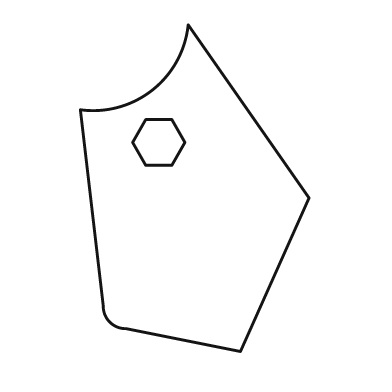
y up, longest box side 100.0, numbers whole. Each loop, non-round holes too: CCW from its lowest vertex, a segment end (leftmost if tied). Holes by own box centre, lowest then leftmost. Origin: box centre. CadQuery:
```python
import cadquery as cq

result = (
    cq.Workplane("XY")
    .moveTo(14.0, -50.0)
    .lineTo(35.0, -3.0)
    .lineTo(-2.0, 50.0)
    .threePointArc((-13.0, 30.0), (-35.0, 24.0))
    .lineTo(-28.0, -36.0)
    .threePointArc((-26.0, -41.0), (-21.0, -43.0))
    .close()
    .moveTo(-15.0, 7.0)
    .lineTo(-7.0, 7.0)
    .lineTo(-3.0, 14.0)
    .lineTo(-7.0, 21.0)
    .lineTo(-15.0, 21.0)
    .lineTo(-19.0, 14.0)
    .close()
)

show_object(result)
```